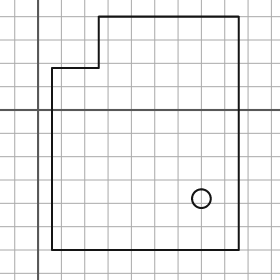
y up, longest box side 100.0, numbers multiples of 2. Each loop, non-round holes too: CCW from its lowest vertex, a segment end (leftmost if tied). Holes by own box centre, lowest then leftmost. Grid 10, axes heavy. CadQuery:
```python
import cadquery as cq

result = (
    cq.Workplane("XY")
    .moveTo(6.0, -60.0)
    .lineTo(86.0, -60.0)
    .lineTo(86.0, 40.0)
    .lineTo(26.0, 40.0)
    .lineTo(26.0, 18.0)
    .lineTo(6.0, 18.0)
    .close()
    .moveTo(70.0, -38.0)
    .circle(4.0)
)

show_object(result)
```